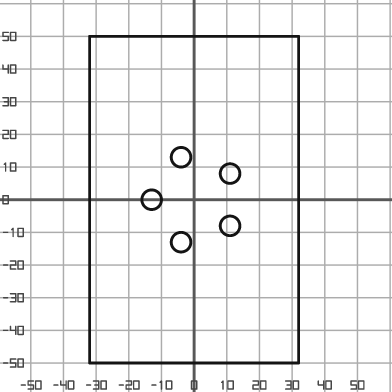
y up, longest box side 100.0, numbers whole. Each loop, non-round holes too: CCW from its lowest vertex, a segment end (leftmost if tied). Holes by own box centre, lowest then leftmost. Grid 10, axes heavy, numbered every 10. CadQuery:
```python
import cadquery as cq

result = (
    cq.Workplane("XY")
    .moveTo(-32.0, -50.0)
    .lineTo(32.0, -50.0)
    .lineTo(32.0, 50.0)
    .lineTo(-32.0, 50.0)
    .close()
    .moveTo(-4.0, -13.0)
    .circle(3.0)
    .moveTo(11.0, -8.0)
    .circle(3.0)
    .moveTo(-13.0, 0.0)
    .circle(3.0)
    .moveTo(11.0, 8.0)
    .circle(3.0)
    .moveTo(-4.0, 13.0)
    .circle(3.0)
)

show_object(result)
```